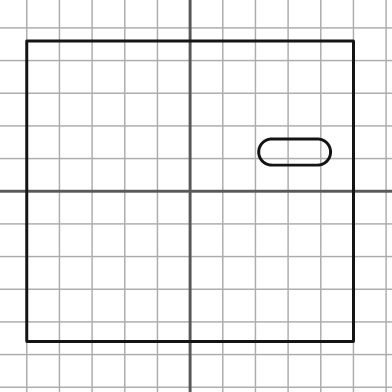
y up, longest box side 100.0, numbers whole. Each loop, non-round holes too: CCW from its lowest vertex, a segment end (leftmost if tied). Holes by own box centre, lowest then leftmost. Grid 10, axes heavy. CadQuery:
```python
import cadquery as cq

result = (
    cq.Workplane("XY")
    .moveTo(-50.0, -46.0)
    .lineTo(50.0, -46.0)
    .lineTo(50.0, 46.0)
    .lineTo(-50.0, 46.0)
    .close()
    .moveTo(25.0, 8.0)
    .lineTo(39.0, 8.0)
    .threePointArc((43.0, 12.0), (39.0, 16.0))
    .lineTo(25.0, 16.0)
    .threePointArc((21.0, 12.0), (25.0, 8.0))
    .close()
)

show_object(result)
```